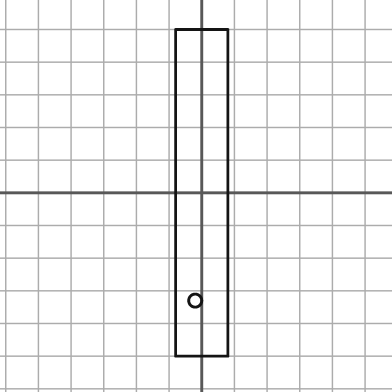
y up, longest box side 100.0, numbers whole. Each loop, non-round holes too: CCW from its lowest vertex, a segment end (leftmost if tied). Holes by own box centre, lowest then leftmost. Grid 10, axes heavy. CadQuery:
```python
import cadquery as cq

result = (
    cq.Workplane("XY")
    .moveTo(-8.0, -50.0)
    .lineTo(8.0, -50.0)
    .lineTo(8.0, 50.0)
    .lineTo(-8.0, 50.0)
    .close()
    .moveTo(-2.0, -33.0)
    .circle(2.0)
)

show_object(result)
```